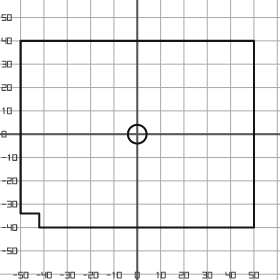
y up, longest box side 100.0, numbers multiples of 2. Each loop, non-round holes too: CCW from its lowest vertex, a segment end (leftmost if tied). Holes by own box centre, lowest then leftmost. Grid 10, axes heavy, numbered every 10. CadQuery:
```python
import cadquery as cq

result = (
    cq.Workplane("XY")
    .moveTo(-42.0, -40.0)
    .lineTo(50.0, -40.0)
    .lineTo(50.0, 40.0)
    .lineTo(-50.0, 40.0)
    .lineTo(-50.0, -34.0)
    .lineTo(-42.0, -34.0)
    .close()
    .moveTo(0.0, 0.0)
    .circle(4.0)
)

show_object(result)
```